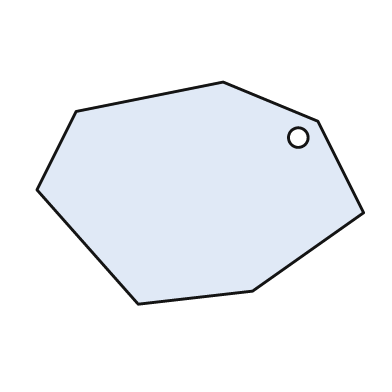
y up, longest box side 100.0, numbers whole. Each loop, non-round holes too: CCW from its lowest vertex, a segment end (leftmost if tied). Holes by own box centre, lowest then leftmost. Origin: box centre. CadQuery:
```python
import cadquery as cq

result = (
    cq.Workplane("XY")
    .moveTo(-19.0, -34.0)
    .lineTo(16.0, -30.0)
    .lineTo(50.0, -6.0)
    .lineTo(36.0, 22.0)
    .lineTo(7.0, 34.0)
    .lineTo(-38.0, 25.0)
    .lineTo(-50.0, 1.0)
    .close()
    .moveTo(30.0, 17.0)
    .circle(3.0)
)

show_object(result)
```